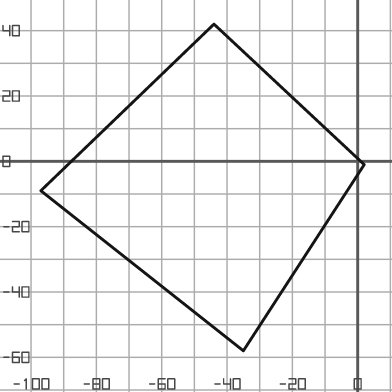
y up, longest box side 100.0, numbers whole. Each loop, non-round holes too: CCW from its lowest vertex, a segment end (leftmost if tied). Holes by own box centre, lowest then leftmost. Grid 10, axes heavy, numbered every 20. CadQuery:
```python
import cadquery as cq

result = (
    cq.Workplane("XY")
    .moveTo(-35.0, -58.0)
    .lineTo(2.0, -1.0)
    .lineTo(-44.0, 42.0)
    .lineTo(-97.0, -9.0)
    .close()
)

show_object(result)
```